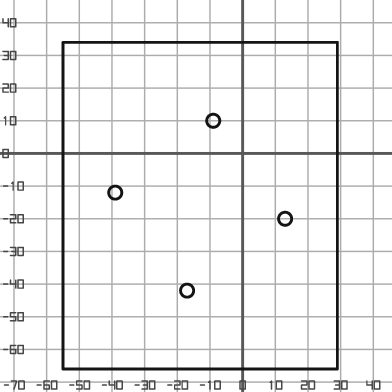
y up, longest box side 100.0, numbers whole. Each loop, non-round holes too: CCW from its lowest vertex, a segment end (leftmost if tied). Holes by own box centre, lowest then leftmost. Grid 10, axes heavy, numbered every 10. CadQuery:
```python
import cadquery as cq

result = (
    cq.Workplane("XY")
    .moveTo(-55.0, -66.0)
    .lineTo(29.0, -66.0)
    .lineTo(29.0, 34.0)
    .lineTo(-55.0, 34.0)
    .close()
    .moveTo(-17.0, -42.0)
    .circle(2.0)
    .moveTo(13.0, -20.0)
    .circle(2.0)
    .moveTo(-39.0, -12.0)
    .circle(2.0)
    .moveTo(-9.0, 10.0)
    .circle(2.0)
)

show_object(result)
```